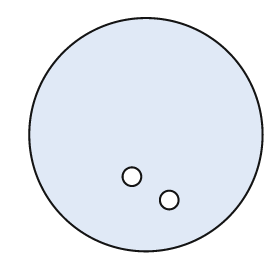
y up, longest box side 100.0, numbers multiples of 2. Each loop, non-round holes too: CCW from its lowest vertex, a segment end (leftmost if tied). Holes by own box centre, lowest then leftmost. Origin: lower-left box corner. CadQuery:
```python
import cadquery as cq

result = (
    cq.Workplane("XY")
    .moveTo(50.0, 50.0)
    .circle(50.0)
    .moveTo(60.0, 22.0)
    .circle(4.0)
    .moveTo(44.0, 32.0)
    .circle(4.0)
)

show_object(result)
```